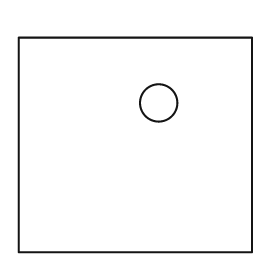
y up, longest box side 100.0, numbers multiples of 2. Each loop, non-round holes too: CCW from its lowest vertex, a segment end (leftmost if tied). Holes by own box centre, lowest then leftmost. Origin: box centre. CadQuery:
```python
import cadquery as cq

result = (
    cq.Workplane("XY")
    .moveTo(-50.0, -46.0)
    .lineTo(50.0, -46.0)
    .lineTo(50.0, 46.0)
    .lineTo(-50.0, 46.0)
    .close()
    .moveTo(10.0, 18.0)
    .circle(8.0)
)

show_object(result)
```